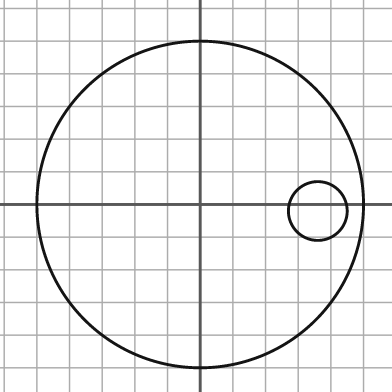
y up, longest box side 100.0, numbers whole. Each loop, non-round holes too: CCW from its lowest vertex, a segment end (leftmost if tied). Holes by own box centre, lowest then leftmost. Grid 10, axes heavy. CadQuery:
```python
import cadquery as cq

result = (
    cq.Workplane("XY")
    .moveTo(0.0, 0.0)
    .circle(50.0)
    .moveTo(36.0, -2.0)
    .circle(9.0)
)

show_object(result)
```